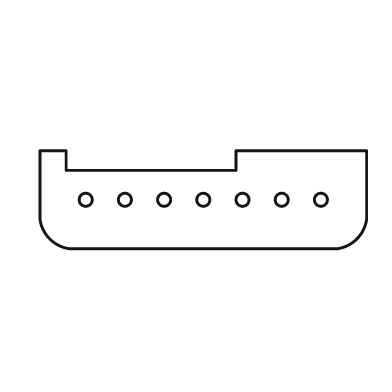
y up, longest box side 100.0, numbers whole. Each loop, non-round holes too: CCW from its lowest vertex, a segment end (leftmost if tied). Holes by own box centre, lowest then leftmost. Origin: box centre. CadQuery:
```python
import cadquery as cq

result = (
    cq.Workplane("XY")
    .moveTo(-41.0, -15.0)
    .lineTo(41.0, -15.0)
    .threePointArc((47.0, -12.0), (50.0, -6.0))
    .lineTo(50.0, 15.0)
    .lineTo(10.0, 15.0)
    .lineTo(10.0, 9.0)
    .lineTo(-42.0, 9.0)
    .lineTo(-42.0, 15.0)
    .lineTo(-50.0, 15.0)
    .lineTo(-50.0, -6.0)
    .threePointArc((-47.0, -12.0), (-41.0, -15.0))
    .close()
    .moveTo(-36.0, 0.0)
    .circle(2.0)
    .moveTo(-24.0, 0.0)
    .circle(2.0)
    .moveTo(-12.0, 0.0)
    .circle(2.0)
    .moveTo(0.0, 0.0)
    .circle(2.0)
    .moveTo(12.0, 0.0)
    .circle(2.0)
    .moveTo(24.0, 0.0)
    .circle(2.0)
    .moveTo(36.0, 0.0)
    .circle(2.0)
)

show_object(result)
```